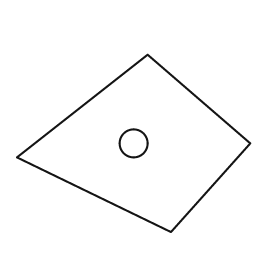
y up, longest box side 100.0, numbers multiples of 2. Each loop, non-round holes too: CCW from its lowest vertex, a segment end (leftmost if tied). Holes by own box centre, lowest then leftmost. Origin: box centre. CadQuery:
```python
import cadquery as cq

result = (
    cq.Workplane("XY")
    .moveTo(16.0, -38.0)
    .lineTo(50.0, 0.0)
    .lineTo(6.0, 38.0)
    .lineTo(-50.0, -6.0)
    .close()
    .moveTo(0.0, 0.0)
    .circle(6.0)
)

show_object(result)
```